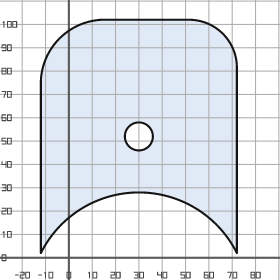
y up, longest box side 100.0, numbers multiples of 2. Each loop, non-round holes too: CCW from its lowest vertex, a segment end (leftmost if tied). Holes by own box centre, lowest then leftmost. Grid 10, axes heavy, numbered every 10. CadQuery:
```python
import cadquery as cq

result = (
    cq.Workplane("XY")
    .moveTo(-12.0, 2.0)
    .threePointArc((30.0, 28.0), (72.0, 2.0))
    .lineTo(72.0, 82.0)
    .threePointArc((66.0, 96.0), (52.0, 102.0))
    .lineTo(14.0, 102.0)
    .threePointArc((-4.0, 94.0), (-12.0, 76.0))
    .close()
    .moveTo(30.0, 52.0)
    .circle(6.0)
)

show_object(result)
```